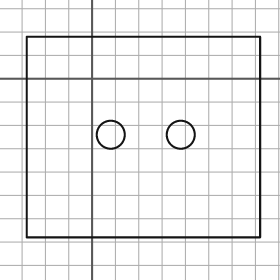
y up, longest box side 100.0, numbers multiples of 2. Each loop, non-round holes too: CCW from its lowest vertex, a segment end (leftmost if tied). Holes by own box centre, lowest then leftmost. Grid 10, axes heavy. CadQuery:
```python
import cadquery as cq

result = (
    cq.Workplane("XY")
    .moveTo(-28.0, -68.0)
    .lineTo(72.0, -68.0)
    .lineTo(72.0, 18.0)
    .lineTo(-28.0, 18.0)
    .close()
    .moveTo(8.0, -24.0)
    .circle(6.0)
    .moveTo(38.0, -24.0)
    .circle(6.0)
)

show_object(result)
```